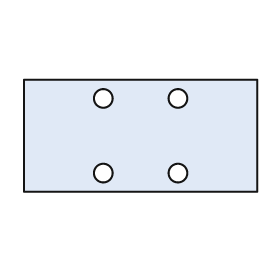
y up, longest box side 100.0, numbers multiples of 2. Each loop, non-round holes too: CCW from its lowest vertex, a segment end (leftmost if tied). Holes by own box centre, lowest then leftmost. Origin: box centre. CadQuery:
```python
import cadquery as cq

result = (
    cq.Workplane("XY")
    .moveTo(-50.0, -24.0)
    .lineTo(50.0, -24.0)
    .lineTo(50.0, 24.0)
    .lineTo(-50.0, 24.0)
    .close()
    .moveTo(-16.0, -16.0)
    .circle(4.0)
    .moveTo(16.0, -16.0)
    .circle(4.0)
    .moveTo(-16.0, 16.0)
    .circle(4.0)
    .moveTo(16.0, 16.0)
    .circle(4.0)
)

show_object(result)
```